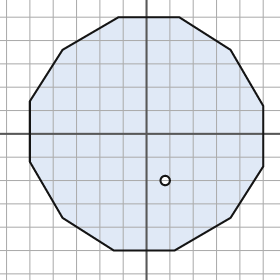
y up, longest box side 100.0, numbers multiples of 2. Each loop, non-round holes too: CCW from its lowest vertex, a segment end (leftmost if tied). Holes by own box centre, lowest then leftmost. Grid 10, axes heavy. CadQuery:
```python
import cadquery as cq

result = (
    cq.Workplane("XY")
    .moveTo(-14.0, -50.0)
    .lineTo(12.0, -50.0)
    .lineTo(36.0, -36.0)
    .lineTo(50.0, -14.0)
    .lineTo(50.0, 12.0)
    .lineTo(36.0, 36.0)
    .lineTo(14.0, 50.0)
    .lineTo(-12.0, 50.0)
    .lineTo(-36.0, 36.0)
    .lineTo(-50.0, 14.0)
    .lineTo(-50.0, -12.0)
    .lineTo(-36.0, -36.0)
    .close()
    .moveTo(8.0, -20.0)
    .circle(2.0)
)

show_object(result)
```